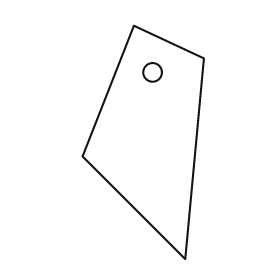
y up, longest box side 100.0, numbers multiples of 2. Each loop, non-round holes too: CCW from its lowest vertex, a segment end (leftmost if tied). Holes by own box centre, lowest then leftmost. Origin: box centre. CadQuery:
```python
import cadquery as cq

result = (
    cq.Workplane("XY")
    .moveTo(18.0, -50.0)
    .lineTo(26.0, 36.0)
    .lineTo(-4.0, 50.0)
    .lineTo(-26.0, -6.0)
    .close()
    .moveTo(4.0, 30.0)
    .circle(4.0)
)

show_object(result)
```